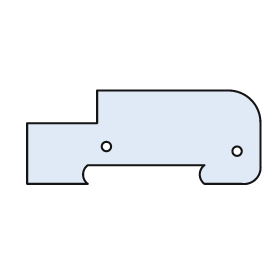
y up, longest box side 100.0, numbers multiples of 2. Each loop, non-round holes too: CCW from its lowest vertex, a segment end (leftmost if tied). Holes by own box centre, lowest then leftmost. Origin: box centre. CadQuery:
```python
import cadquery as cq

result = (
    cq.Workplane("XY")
    .moveTo(-50.0, -20.0)
    .lineTo(-24.0, -20.0)
    .threePointArc((-26.0, -16.0), (-24.0, -12.0))
    .lineTo(26.0, -12.0)
    .threePointArc((24.0, -16.0), (26.0, -20.0))
    .lineTo(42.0, -20.0)
    .threePointArc((48.0, -18.0), (50.0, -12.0))
    .lineTo(50.0, 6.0)
    .threePointArc((46.0, 16.0), (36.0, 20.0))
    .lineTo(-20.0, 20.0)
    .lineTo(-20.0, 6.0)
    .lineTo(-50.0, 6.0)
    .close()
    .moveTo(40.0, -6.0)
    .circle(2.0)
    .moveTo(-16.0, -4.0)
    .circle(2.0)
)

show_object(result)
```